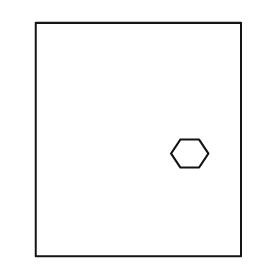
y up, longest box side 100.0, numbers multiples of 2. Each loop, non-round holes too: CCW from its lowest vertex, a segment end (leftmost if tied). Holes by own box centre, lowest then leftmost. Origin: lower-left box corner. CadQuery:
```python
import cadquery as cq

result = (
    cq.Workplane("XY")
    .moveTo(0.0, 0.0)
    .lineTo(88.0, 0.0)
    .lineTo(88.0, 100.0)
    .lineTo(0.0, 100.0)
    .close()
    .moveTo(62.0, 38.0)
    .lineTo(70.0, 38.0)
    .lineTo(74.0, 44.0)
    .lineTo(70.0, 50.0)
    .lineTo(62.0, 50.0)
    .lineTo(58.0, 44.0)
    .close()
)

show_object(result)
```